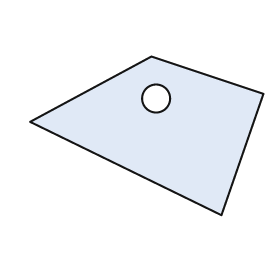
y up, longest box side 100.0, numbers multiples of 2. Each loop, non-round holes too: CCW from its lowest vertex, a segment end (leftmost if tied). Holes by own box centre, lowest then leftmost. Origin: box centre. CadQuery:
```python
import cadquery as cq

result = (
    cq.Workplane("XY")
    .moveTo(32.0, -34.0)
    .lineTo(50.0, 18.0)
    .lineTo(2.0, 34.0)
    .lineTo(-50.0, 6.0)
    .close()
    .moveTo(4.0, 16.0)
    .circle(6.0)
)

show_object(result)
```